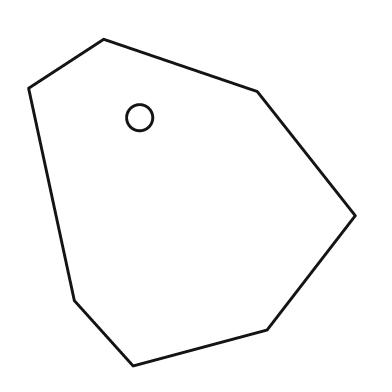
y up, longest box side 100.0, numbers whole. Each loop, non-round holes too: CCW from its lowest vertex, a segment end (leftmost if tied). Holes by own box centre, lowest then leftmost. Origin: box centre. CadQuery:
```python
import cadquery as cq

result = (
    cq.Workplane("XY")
    .moveTo(-18.0, -50.0)
    .lineTo(23.0, -39.0)
    .lineTo(50.0, -4.0)
    .lineTo(20.0, 34.0)
    .lineTo(-27.0, 50.0)
    .lineTo(-50.0, 35.0)
    .lineTo(-36.0, -30.0)
    .close()
    .moveTo(-16.0, 26.0)
    .circle(4.0)
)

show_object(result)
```